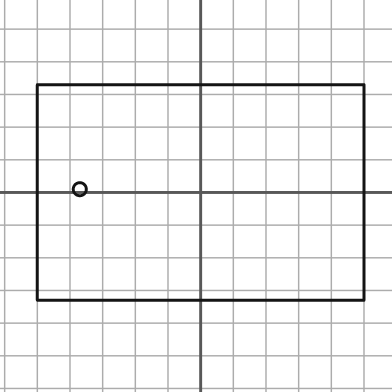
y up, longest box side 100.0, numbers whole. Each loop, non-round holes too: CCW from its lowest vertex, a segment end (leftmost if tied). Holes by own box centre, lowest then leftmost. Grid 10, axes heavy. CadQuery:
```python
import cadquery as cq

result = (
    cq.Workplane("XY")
    .moveTo(-50.0, -33.0)
    .lineTo(50.0, -33.0)
    .lineTo(50.0, 33.0)
    .lineTo(-50.0, 33.0)
    .close()
    .moveTo(-37.0, 1.0)
    .circle(2.0)
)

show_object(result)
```